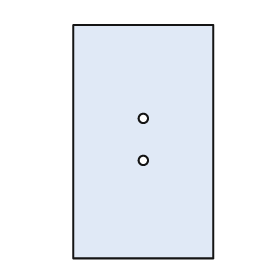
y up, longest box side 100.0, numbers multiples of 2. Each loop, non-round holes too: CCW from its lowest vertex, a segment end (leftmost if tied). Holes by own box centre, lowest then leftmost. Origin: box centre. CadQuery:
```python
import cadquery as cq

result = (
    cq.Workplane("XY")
    .moveTo(-30.0, -50.0)
    .lineTo(30.0, -50.0)
    .lineTo(30.0, 50.0)
    .lineTo(-30.0, 50.0)
    .close()
    .moveTo(0.0, -8.0)
    .circle(2.0)
    .moveTo(0.0, 10.0)
    .circle(2.0)
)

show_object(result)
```